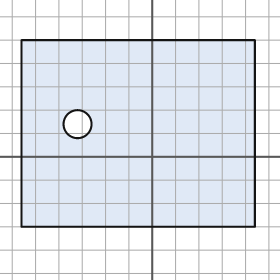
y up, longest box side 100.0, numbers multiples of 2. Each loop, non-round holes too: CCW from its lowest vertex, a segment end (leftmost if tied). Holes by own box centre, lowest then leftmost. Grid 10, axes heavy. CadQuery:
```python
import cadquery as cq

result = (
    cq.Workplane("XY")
    .moveTo(-56.0, -30.0)
    .lineTo(44.0, -30.0)
    .lineTo(44.0, 50.0)
    .lineTo(-56.0, 50.0)
    .close()
    .moveTo(-32.0, 14.0)
    .circle(6.0)
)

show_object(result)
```